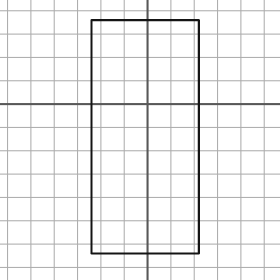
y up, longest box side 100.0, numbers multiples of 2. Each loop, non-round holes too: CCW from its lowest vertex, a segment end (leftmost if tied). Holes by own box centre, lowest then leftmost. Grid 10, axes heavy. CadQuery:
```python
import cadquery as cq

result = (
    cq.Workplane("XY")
    .moveTo(-24.0, -64.0)
    .lineTo(22.0, -64.0)
    .lineTo(22.0, 36.0)
    .lineTo(-24.0, 36.0)
    .close()
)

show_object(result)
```